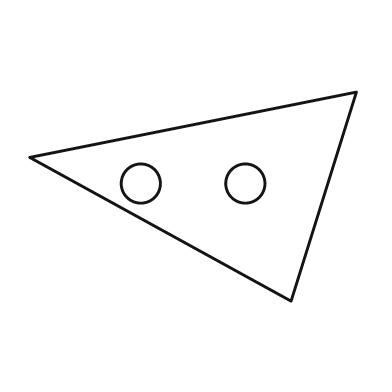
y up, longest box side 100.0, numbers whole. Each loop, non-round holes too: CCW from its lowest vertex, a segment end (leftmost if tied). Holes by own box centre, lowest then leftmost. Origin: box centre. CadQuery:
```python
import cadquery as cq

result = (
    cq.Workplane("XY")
    .moveTo(30.0, -32.0)
    .lineTo(50.0, 32.0)
    .lineTo(-50.0, 12.0)
    .close()
    .moveTo(-16.0, 4.0)
    .circle(6.0)
    .moveTo(16.0, 4.0)
    .circle(6.0)
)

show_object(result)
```